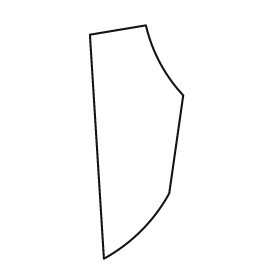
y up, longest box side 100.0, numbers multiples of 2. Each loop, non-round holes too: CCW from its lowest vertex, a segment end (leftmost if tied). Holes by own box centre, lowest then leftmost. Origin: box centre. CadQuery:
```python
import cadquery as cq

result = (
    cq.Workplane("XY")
    .moveTo(-14.0, -50.0)
    .threePointArc((2.0, -38.0), (14.0, -22.0))
    .lineTo(20.0, 20.0)
    .threePointArc((10.0, 34.0), (4.0, 50.0))
    .lineTo(-20.0, 46.0)
    .close()
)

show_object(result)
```